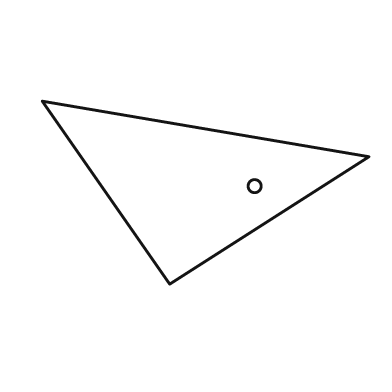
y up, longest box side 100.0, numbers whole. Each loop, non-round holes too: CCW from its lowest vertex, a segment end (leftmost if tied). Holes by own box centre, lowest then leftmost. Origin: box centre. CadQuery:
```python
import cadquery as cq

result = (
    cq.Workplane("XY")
    .moveTo(-11.0, -28.0)
    .lineTo(50.0, 11.0)
    .lineTo(-50.0, 28.0)
    .close()
    .moveTo(15.0, 2.0)
    .circle(2.0)
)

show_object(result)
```